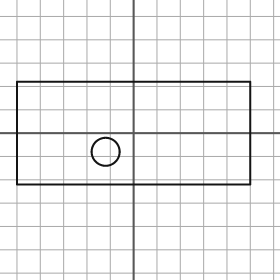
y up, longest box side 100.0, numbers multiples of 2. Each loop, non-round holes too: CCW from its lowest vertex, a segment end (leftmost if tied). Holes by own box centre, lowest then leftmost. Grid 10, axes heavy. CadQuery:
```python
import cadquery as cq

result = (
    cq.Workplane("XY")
    .moveTo(-50.0, -22.0)
    .lineTo(50.0, -22.0)
    .lineTo(50.0, 22.0)
    .lineTo(-50.0, 22.0)
    .close()
    .moveTo(-12.0, -8.0)
    .circle(6.0)
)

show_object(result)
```